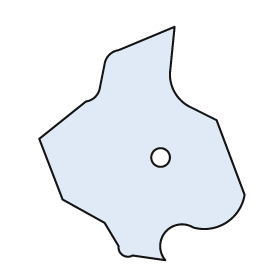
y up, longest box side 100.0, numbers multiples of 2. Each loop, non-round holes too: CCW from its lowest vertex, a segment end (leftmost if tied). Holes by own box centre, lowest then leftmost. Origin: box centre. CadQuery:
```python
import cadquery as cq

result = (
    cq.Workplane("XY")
    .moveTo(10.0, -50.0)
    .threePointArc((10.0, -38.0), (22.0, -36.0))
    .threePointArc((36.0, -34.0), (44.0, -22.0))
    .lineTo(32.0, 10.0)
    .lineTo(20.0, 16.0)
    .threePointArc((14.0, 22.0), (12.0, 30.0))
    .lineTo(14.0, 50.0)
    .lineTo(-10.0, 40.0)
    .threePointArc((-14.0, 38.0), (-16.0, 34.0))
    .lineTo(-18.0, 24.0)
    .threePointArc((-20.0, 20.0), (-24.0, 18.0))
    .lineTo(-44.0, 2.0)
    .lineTo(-34.0, -24.0)
    .lineTo(-16.0, -34.0)
    .lineTo(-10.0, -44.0)
    .threePointArc((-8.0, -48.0), (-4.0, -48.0))
    .close()
    .moveTo(8.0, -6.0)
    .circle(4.0)
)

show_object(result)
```